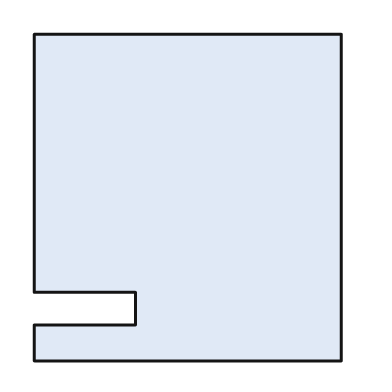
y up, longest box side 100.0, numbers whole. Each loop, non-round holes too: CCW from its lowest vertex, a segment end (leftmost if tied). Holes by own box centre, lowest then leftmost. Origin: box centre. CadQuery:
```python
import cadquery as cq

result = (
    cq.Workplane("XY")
    .moveTo(-47.0, -50.0)
    .lineTo(47.0, -50.0)
    .lineTo(47.0, 50.0)
    .lineTo(-47.0, 50.0)
    .lineTo(-47.0, -29.0)
    .lineTo(-16.0, -29.0)
    .lineTo(-16.0, -39.0)
    .lineTo(-47.0, -39.0)
    .close()
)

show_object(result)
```